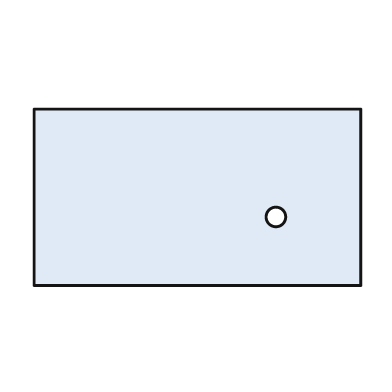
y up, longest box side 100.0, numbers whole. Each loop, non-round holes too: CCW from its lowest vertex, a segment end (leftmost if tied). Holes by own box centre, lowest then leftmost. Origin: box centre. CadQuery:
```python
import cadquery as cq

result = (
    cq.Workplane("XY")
    .moveTo(-50.0, -27.0)
    .lineTo(50.0, -27.0)
    .lineTo(50.0, 27.0)
    .lineTo(-50.0, 27.0)
    .close()
    .moveTo(24.0, -6.0)
    .circle(3.0)
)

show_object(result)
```